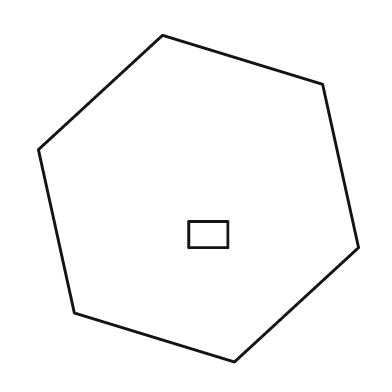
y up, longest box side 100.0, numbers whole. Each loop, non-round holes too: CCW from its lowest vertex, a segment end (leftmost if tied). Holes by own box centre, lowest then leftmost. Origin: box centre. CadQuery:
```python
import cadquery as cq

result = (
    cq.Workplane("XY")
    .moveTo(11.0, -50.0)
    .lineTo(49.0, -15.0)
    .lineTo(38.0, 35.0)
    .lineTo(-11.0, 50.0)
    .lineTo(-49.0, 15.0)
    .lineTo(-38.0, -35.0)
    .close()
    .moveTo(-3.0, -15.0)
    .lineTo(9.0, -15.0)
    .lineTo(9.0, -7.0)
    .lineTo(-3.0, -7.0)
    .close()
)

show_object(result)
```